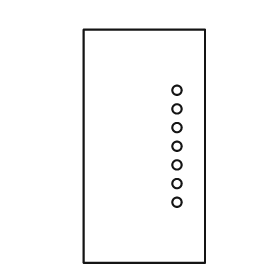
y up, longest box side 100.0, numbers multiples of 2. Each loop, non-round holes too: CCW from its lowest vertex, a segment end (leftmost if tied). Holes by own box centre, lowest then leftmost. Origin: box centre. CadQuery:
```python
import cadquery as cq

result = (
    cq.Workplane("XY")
    .moveTo(-26.0, -50.0)
    .lineTo(26.0, -50.0)
    .lineTo(26.0, 50.0)
    .lineTo(-26.0, 50.0)
    .close()
    .moveTo(14.0, -24.0)
    .circle(2.0)
    .moveTo(14.0, -16.0)
    .circle(2.0)
    .moveTo(14.0, -8.0)
    .circle(2.0)
    .moveTo(14.0, 0.0)
    .circle(2.0)
    .moveTo(14.0, 8.0)
    .circle(2.0)
    .moveTo(14.0, 16.0)
    .circle(2.0)
    .moveTo(14.0, 24.0)
    .circle(2.0)
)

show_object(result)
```